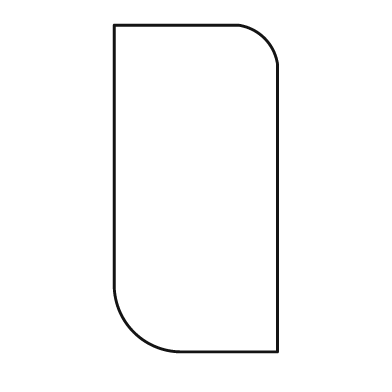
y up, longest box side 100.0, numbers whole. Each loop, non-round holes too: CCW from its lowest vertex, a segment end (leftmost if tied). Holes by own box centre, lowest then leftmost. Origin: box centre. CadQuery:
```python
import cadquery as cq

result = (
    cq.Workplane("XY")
    .moveTo(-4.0, -50.0)
    .lineTo(25.0, -50.0)
    .lineTo(25.0, 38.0)
    .threePointArc((21.0, 46.0), (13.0, 50.0))
    .lineTo(-25.0, 50.0)
    .lineTo(-25.0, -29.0)
    .threePointArc((-19.0, -44.0), (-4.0, -50.0))
    .close()
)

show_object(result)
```